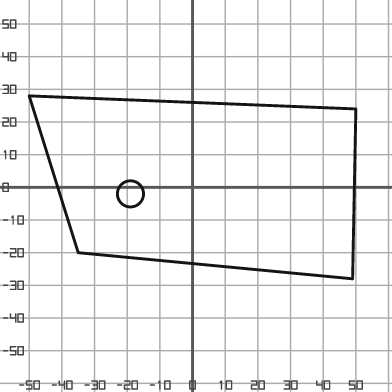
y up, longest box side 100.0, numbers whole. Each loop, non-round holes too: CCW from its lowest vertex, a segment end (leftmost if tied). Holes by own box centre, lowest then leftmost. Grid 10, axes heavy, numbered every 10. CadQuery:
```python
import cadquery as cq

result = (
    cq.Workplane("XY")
    .moveTo(49.0, -28.0)
    .lineTo(50.0, 24.0)
    .lineTo(-50.0, 28.0)
    .lineTo(-35.0, -20.0)
    .close()
    .moveTo(-19.0, -2.0)
    .circle(4.0)
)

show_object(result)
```